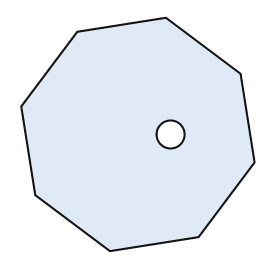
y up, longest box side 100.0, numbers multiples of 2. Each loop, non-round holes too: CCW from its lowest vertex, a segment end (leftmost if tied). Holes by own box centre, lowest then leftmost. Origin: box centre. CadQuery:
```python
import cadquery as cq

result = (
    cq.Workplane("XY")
    .moveTo(-12.0, -50.0)
    .lineTo(26.0, -44.0)
    .lineTo(50.0, -12.0)
    .lineTo(44.0, 26.0)
    .lineTo(12.0, 50.0)
    .lineTo(-26.0, 44.0)
    .lineTo(-50.0, 12.0)
    .lineTo(-44.0, -26.0)
    .close()
    .moveTo(14.0, 0.0)
    .circle(6.0)
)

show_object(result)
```